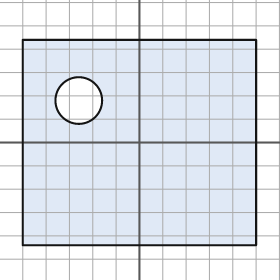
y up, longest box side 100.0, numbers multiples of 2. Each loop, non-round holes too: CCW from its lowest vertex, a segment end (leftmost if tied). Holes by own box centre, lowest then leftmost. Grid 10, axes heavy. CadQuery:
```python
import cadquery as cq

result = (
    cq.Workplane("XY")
    .moveTo(-50.0, -44.0)
    .lineTo(50.0, -44.0)
    .lineTo(50.0, 44.0)
    .lineTo(-50.0, 44.0)
    .close()
    .moveTo(-26.0, 18.0)
    .circle(10.0)
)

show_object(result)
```